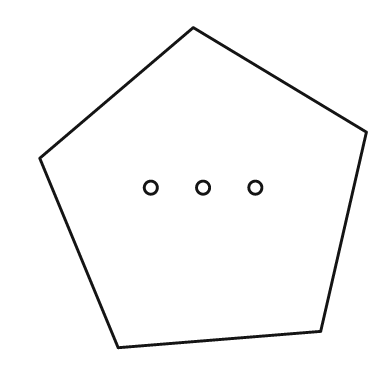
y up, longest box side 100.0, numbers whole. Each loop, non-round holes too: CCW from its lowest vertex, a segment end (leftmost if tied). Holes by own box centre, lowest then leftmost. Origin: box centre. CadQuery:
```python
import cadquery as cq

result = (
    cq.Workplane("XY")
    .moveTo(-26.0, -49.0)
    .lineTo(36.0, -44.0)
    .lineTo(50.0, 17.0)
    .lineTo(-3.0, 49.0)
    .lineTo(-50.0, 9.0)
    .close()
    .moveTo(-16.0, 0.0)
    .circle(2.0)
    .moveTo(0.0, 0.0)
    .circle(2.0)
    .moveTo(16.0, 0.0)
    .circle(2.0)
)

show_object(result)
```